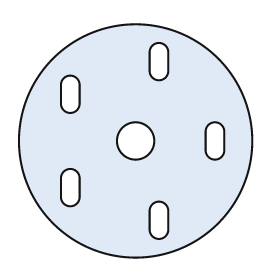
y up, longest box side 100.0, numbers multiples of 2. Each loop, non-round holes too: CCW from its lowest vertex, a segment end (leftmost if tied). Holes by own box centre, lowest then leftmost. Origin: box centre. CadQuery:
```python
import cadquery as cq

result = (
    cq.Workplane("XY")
    .moveTo(0.0, 0.0)
    .circle(50.0)
    .moveTo(6.0, -38.0)
    .threePointArc((10.0, -42.0), (14.0, -38.0))
    .lineTo(14.0, -30.0)
    .threePointArc((10.0, -26.0), (6.0, -30.0))
    .close()
    .moveTo(-32.0, -24.0)
    .threePointArc((-28.0, -28.0), (-24.0, -24.0))
    .lineTo(-24.0, -16.0)
    .threePointArc((-28.0, -12.0), (-32.0, -16.0))
    .close()
    .moveTo(0.0, 0.0)
    .circle(8.0)
    .moveTo(30.0, -4.0)
    .threePointArc((34.0, -8.0), (38.0, -4.0))
    .lineTo(38.0, 4.0)
    .threePointArc((34.0, 8.0), (30.0, 4.0))
    .close()
    .moveTo(-32.0, 16.0)
    .threePointArc((-28.0, 12.0), (-24.0, 16.0))
    .lineTo(-24.0, 24.0)
    .threePointArc((-28.0, 28.0), (-32.0, 24.0))
    .close()
    .moveTo(6.0, 30.0)
    .threePointArc((10.0, 26.0), (14.0, 30.0))
    .lineTo(14.0, 38.0)
    .threePointArc((10.0, 42.0), (6.0, 38.0))
    .close()
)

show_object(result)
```